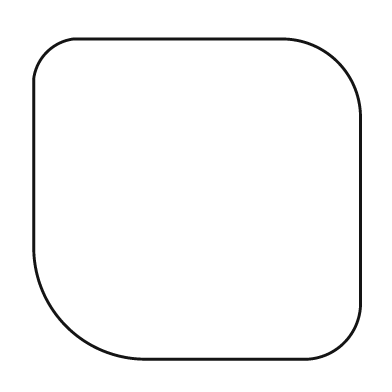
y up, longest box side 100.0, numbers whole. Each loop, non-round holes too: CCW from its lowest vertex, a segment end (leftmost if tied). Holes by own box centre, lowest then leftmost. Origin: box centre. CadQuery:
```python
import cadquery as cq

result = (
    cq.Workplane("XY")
    .moveTo(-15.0, -49.0)
    .lineTo(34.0, -49.0)
    .threePointArc((45.0, -44.0), (50.0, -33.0))
    .lineTo(50.0, 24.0)
    .threePointArc((43.0, 42.0), (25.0, 49.0))
    .lineTo(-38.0, 49.0)
    .threePointArc((-46.0, 45.0), (-50.0, 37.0))
    .lineTo(-50.0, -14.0)
    .threePointArc((-40.0, -39.0), (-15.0, -49.0))
    .close()
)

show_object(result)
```